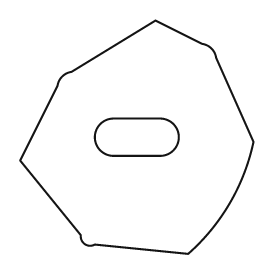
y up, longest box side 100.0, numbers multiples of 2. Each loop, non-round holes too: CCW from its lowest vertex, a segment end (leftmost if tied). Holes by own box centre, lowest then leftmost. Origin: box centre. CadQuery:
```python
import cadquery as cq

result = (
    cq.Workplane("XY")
    .moveTo(22.0, -50.0)
    .threePointArc((40.0, -28.0), (50.0, -2.0))
    .lineTo(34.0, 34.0)
    .threePointArc((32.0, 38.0), (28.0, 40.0))
    .lineTo(8.0, 50.0)
    .lineTo(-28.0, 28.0)
    .threePointArc((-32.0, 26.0), (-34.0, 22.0))
    .lineTo(-50.0, -10.0)
    .lineTo(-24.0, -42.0)
    .threePointArc((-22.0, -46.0), (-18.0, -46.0))
    .close()
    .moveTo(-10.0, -8.0)
    .lineTo(10.0, -8.0)
    .threePointArc((18.0, 0.0), (10.0, 8.0))
    .lineTo(-10.0, 8.0)
    .threePointArc((-18.0, 0.0), (-10.0, -8.0))
    .close()
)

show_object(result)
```